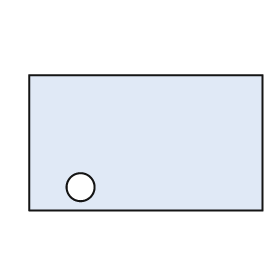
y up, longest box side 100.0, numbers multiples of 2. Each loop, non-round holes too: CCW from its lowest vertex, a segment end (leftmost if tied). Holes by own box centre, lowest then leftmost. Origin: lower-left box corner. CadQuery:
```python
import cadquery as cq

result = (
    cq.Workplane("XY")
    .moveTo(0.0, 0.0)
    .lineTo(100.0, 0.0)
    .lineTo(100.0, 58.0)
    .lineTo(0.0, 58.0)
    .close()
    .moveTo(22.0, 10.0)
    .circle(6.0)
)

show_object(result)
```